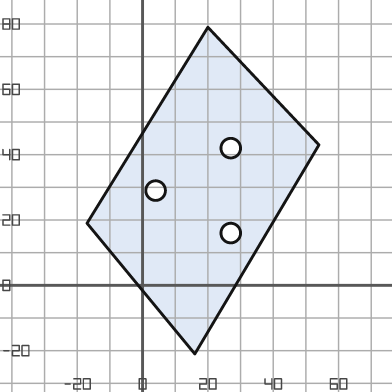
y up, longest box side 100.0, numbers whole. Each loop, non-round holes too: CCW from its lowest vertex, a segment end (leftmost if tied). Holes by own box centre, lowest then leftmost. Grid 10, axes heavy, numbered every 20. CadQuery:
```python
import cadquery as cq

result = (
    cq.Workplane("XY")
    .moveTo(16.0, -21.0)
    .lineTo(54.0, 43.0)
    .lineTo(20.0, 79.0)
    .lineTo(-17.0, 19.0)
    .close()
    .moveTo(27.0, 16.0)
    .circle(3.0)
    .moveTo(4.0, 29.0)
    .circle(3.0)
    .moveTo(27.0, 42.0)
    .circle(3.0)
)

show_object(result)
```